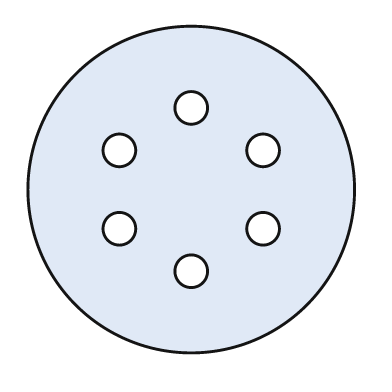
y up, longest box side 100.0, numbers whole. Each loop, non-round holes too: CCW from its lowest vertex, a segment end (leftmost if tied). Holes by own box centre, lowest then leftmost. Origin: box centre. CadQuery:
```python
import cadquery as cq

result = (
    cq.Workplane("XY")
    .moveTo(0.0, 0.0)
    .circle(50.0)
    .moveTo(0.0, -25.0)
    .circle(5.0)
    .moveTo(-22.0, -12.0)
    .circle(5.0)
    .moveTo(22.0, -12.0)
    .circle(5.0)
    .moveTo(-22.0, 12.0)
    .circle(5.0)
    .moveTo(22.0, 12.0)
    .circle(5.0)
    .moveTo(0.0, 25.0)
    .circle(5.0)
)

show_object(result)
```